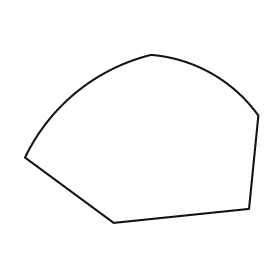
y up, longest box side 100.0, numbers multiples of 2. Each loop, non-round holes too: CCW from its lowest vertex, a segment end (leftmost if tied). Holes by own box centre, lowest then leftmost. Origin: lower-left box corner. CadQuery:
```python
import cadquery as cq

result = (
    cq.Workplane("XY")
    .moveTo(38.0, 0.0)
    .lineTo(96.0, 6.0)
    .lineTo(100.0, 46.0)
    .threePointArc((80.0, 64.0), (54.0, 72.0))
    .threePointArc((22.0, 56.0), (0.0, 28.0))
    .close()
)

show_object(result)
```